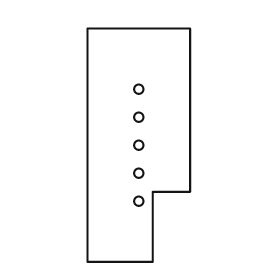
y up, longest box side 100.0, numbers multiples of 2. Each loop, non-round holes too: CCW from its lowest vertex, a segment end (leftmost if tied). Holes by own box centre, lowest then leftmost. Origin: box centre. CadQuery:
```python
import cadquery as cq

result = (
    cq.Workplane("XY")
    .moveTo(-22.0, -50.0)
    .lineTo(6.0, -50.0)
    .lineTo(6.0, -20.0)
    .lineTo(22.0, -20.0)
    .lineTo(22.0, 50.0)
    .lineTo(-22.0, 50.0)
    .close()
    .moveTo(0.0, -24.0)
    .circle(2.0)
    .moveTo(0.0, -12.0)
    .circle(2.0)
    .moveTo(0.0, 0.0)
    .circle(2.0)
    .moveTo(0.0, 12.0)
    .circle(2.0)
    .moveTo(0.0, 24.0)
    .circle(2.0)
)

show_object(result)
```